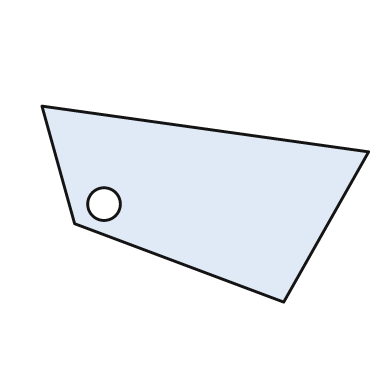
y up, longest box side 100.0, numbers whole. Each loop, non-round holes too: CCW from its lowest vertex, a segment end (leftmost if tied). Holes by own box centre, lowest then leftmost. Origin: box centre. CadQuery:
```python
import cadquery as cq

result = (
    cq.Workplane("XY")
    .moveTo(24.0, -30.0)
    .lineTo(50.0, 16.0)
    .lineTo(-50.0, 30.0)
    .lineTo(-40.0, -6.0)
    .close()
    .moveTo(-31.0, 0.0)
    .circle(5.0)
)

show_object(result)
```